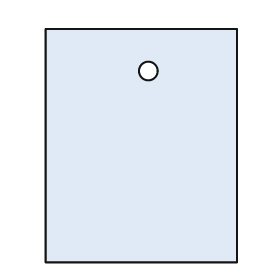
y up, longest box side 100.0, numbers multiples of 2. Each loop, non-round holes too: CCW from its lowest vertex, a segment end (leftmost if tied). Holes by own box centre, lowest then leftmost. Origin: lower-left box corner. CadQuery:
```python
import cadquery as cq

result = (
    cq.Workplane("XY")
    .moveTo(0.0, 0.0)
    .lineTo(82.0, 0.0)
    .lineTo(82.0, 100.0)
    .lineTo(0.0, 100.0)
    .close()
    .moveTo(44.0, 82.0)
    .circle(4.0)
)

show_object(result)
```